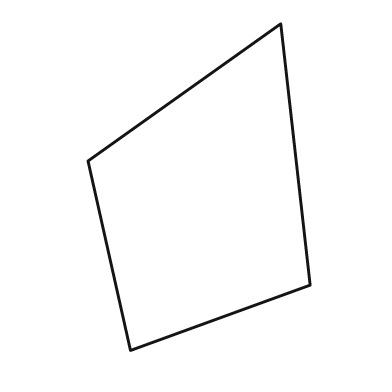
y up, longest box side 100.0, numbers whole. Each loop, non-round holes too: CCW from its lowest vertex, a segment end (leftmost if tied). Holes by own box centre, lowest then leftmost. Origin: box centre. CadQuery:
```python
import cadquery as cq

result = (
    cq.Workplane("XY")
    .moveTo(-21.0, -50.0)
    .lineTo(34.0, -30.0)
    .lineTo(25.0, 50.0)
    .lineTo(-34.0, 8.0)
    .close()
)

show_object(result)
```